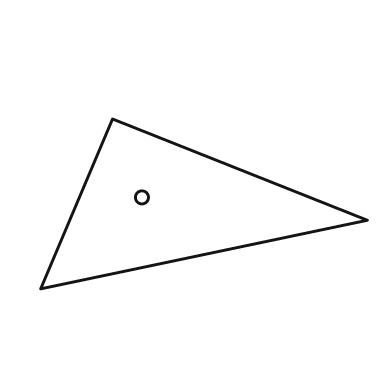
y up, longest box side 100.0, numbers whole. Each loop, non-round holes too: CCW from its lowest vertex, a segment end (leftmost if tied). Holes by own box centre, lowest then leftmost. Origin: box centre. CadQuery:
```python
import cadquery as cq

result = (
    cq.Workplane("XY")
    .moveTo(-50.0, -26.0)
    .lineTo(50.0, -5.0)
    .lineTo(-28.0, 26.0)
    .close()
    .moveTo(-19.0, 2.0)
    .circle(2.0)
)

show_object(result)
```